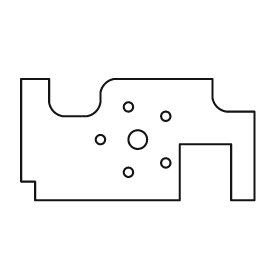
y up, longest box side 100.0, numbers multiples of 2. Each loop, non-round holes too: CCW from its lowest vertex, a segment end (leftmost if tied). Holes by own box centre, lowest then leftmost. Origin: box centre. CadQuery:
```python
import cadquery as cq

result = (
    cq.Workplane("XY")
    .moveTo(-44.0, -26.0)
    .lineTo(18.0, -26.0)
    .lineTo(18.0, -2.0)
    .lineTo(40.0, -2.0)
    .lineTo(40.0, -26.0)
    .lineTo(50.0, -26.0)
    .lineTo(50.0, 12.0)
    .lineTo(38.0, 12.0)
    .threePointArc((34.0, 14.0), (32.0, 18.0))
    .lineTo(32.0, 26.0)
    .lineTo(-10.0, 26.0)
    .threePointArc((-14.0, 24.0), (-16.0, 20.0))
    .lineTo(-16.0, 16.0)
    .threePointArc((-18.0, 12.0), (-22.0, 10.0))
    .lineTo(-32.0, 10.0)
    .threePointArc((-36.0, 12.0), (-38.0, 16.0))
    .lineTo(-38.0, 26.0)
    .lineTo(-50.0, 26.0)
    .lineTo(-50.0, -18.0)
    .lineTo(-44.0, -18.0)
    .close()
    .moveTo(-4.0, -14.0)
    .circle(2.0)
    .moveTo(12.0, -10.0)
    .circle(2.0)
    .moveTo(-16.0, 0.0)
    .circle(2.0)
    .moveTo(0.0, 0.0)
    .circle(4.0)
    .moveTo(12.0, 10.0)
    .circle(2.0)
    .moveTo(-4.0, 14.0)
    .circle(2.0)
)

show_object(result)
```